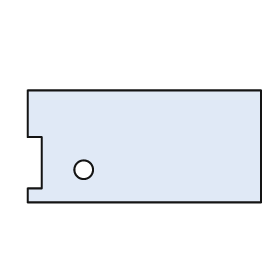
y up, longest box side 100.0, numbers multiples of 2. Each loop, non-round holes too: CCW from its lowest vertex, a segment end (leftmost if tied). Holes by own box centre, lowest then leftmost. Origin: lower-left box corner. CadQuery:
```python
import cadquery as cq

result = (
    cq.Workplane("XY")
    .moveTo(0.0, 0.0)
    .lineTo(100.0, 0.0)
    .lineTo(100.0, 48.0)
    .lineTo(0.0, 48.0)
    .lineTo(0.0, 28.0)
    .lineTo(6.0, 28.0)
    .lineTo(6.0, 6.0)
    .lineTo(0.0, 6.0)
    .close()
    .moveTo(24.0, 14.0)
    .circle(4.0)
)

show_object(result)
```